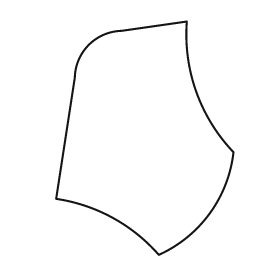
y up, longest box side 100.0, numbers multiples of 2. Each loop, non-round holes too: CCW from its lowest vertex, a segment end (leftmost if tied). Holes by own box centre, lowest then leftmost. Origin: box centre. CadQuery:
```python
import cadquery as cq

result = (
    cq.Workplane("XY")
    .moveTo(6.0, -50.0)
    .threePointArc((28.0, -32.0), (38.0, -6.0))
    .threePointArc((22.0, 20.0), (18.0, 50.0))
    .lineTo(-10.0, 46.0)
    .threePointArc((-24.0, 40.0), (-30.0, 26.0))
    .lineTo(-38.0, -26.0)
    .threePointArc((-14.0, -34.0), (6.0, -50.0))
    .close()
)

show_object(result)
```